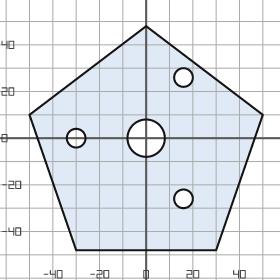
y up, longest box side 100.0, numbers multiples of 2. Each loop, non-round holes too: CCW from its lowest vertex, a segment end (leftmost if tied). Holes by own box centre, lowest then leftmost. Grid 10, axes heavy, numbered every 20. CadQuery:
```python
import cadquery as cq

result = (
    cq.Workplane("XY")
    .moveTo(-30.0, -48.0)
    .lineTo(30.0, -48.0)
    .lineTo(50.0, 10.0)
    .lineTo(0.0, 48.0)
    .lineTo(-50.0, 10.0)
    .close()
    .moveTo(16.0, -26.0)
    .circle(4.0)
    .moveTo(-30.0, 0.0)
    .circle(4.0)
    .moveTo(0.0, 0.0)
    .circle(8.0)
    .moveTo(16.0, 26.0)
    .circle(4.0)
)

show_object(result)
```